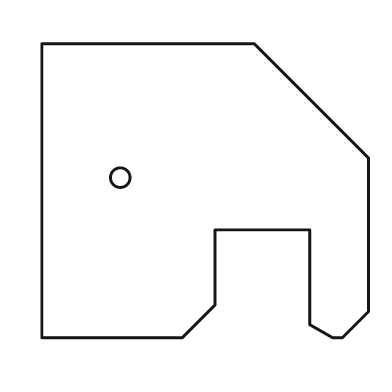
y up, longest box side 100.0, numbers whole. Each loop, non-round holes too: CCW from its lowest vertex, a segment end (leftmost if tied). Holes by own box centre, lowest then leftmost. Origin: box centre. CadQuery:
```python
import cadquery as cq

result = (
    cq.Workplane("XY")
    .moveTo(-50.0, -45.0)
    .lineTo(-7.0, -45.0)
    .lineTo(3.0, -35.0)
    .lineTo(3.0, -12.0)
    .lineTo(32.0, -12.0)
    .lineTo(32.0, -41.0)
    .lineTo(39.0, -45.0)
    .lineTo(42.0, -45.0)
    .lineTo(50.0, -37.0)
    .lineTo(50.0, 10.0)
    .lineTo(15.0, 45.0)
    .lineTo(-50.0, 45.0)
    .close()
    .moveTo(-26.0, 4.0)
    .circle(3.0)
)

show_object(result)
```